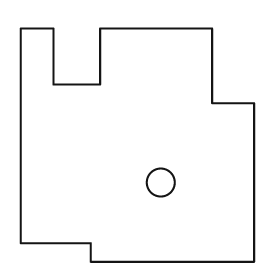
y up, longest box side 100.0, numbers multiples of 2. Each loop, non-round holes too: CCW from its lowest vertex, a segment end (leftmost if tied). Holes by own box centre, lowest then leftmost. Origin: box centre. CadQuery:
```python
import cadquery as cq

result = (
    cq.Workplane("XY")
    .moveTo(-20.0, -50.0)
    .lineTo(50.0, -50.0)
    .lineTo(50.0, 18.0)
    .lineTo(32.0, 18.0)
    .lineTo(32.0, 50.0)
    .lineTo(-16.0, 50.0)
    .lineTo(-16.0, 26.0)
    .lineTo(-36.0, 26.0)
    .lineTo(-36.0, 50.0)
    .lineTo(-50.0, 50.0)
    .lineTo(-50.0, -42.0)
    .lineTo(-20.0, -42.0)
    .close()
    .moveTo(10.0, -16.0)
    .circle(6.0)
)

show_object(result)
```